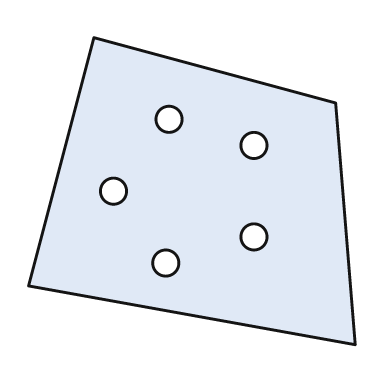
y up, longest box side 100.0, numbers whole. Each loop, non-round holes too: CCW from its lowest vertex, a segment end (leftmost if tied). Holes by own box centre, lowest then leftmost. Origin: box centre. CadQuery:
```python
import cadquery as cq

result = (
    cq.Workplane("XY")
    .moveTo(50.0, -47.0)
    .lineTo(44.0, 27.0)
    .lineTo(-30.0, 47.0)
    .lineTo(-50.0, -29.0)
    .close()
    .moveTo(-8.0, -22.0)
    .circle(4.0)
    .moveTo(19.0, -14.0)
    .circle(4.0)
    .moveTo(-24.0, 0.0)
    .circle(4.0)
    .moveTo(19.0, 14.0)
    .circle(4.0)
    .moveTo(-7.0, 22.0)
    .circle(4.0)
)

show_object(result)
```